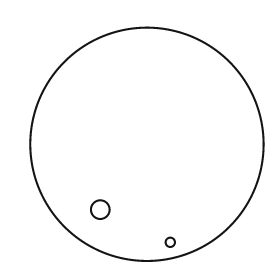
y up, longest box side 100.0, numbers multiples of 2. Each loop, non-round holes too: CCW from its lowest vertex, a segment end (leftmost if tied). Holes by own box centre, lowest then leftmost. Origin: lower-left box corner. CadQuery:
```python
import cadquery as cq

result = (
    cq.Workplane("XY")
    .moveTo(50.0, 50.0)
    .circle(50.0)
    .moveTo(60.0, 8.0)
    .circle(2.0)
    .moveTo(30.0, 22.0)
    .circle(4.0)
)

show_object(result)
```